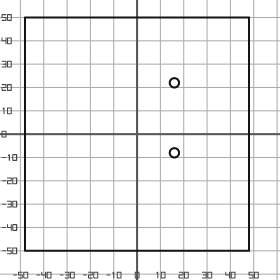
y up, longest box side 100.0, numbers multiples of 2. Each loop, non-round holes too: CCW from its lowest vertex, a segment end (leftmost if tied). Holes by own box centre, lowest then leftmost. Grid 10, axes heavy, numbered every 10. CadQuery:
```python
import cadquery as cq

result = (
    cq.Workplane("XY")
    .moveTo(-48.0, -50.0)
    .lineTo(48.0, -50.0)
    .lineTo(48.0, 50.0)
    .lineTo(-48.0, 50.0)
    .close()
    .moveTo(16.0, -8.0)
    .circle(2.0)
    .moveTo(16.0, 22.0)
    .circle(2.0)
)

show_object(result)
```